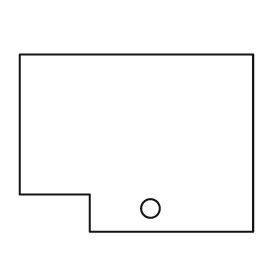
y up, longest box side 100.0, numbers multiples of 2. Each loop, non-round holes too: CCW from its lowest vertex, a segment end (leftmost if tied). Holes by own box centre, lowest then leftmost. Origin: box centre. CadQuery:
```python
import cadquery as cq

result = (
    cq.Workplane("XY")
    .moveTo(-20.0, -38.0)
    .lineTo(50.0, -38.0)
    .lineTo(50.0, 38.0)
    .lineTo(-50.0, 38.0)
    .lineTo(-50.0, -22.0)
    .lineTo(-20.0, -22.0)
    .close()
    .moveTo(6.0, -28.0)
    .circle(4.0)
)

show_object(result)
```